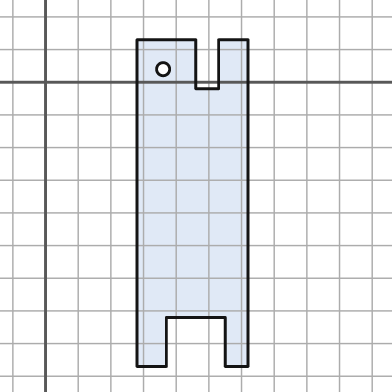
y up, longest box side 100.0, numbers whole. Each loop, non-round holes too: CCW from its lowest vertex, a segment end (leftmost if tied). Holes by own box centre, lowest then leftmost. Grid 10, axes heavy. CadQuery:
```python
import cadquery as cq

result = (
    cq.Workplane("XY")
    .moveTo(28.0, -87.0)
    .lineTo(37.0, -87.0)
    .lineTo(37.0, -72.0)
    .lineTo(55.0, -72.0)
    .lineTo(55.0, -87.0)
    .lineTo(62.0, -87.0)
    .lineTo(62.0, 13.0)
    .lineTo(53.0, 13.0)
    .lineTo(53.0, -2.0)
    .lineTo(46.0, -2.0)
    .lineTo(46.0, 13.0)
    .lineTo(28.0, 13.0)
    .close()
    .moveTo(36.0, 4.0)
    .circle(2.0)
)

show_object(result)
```